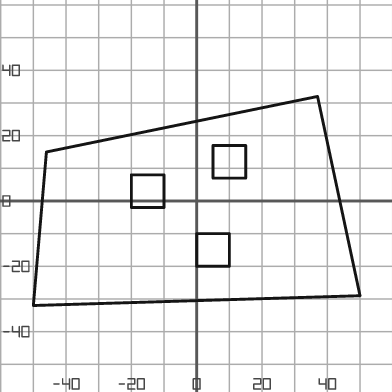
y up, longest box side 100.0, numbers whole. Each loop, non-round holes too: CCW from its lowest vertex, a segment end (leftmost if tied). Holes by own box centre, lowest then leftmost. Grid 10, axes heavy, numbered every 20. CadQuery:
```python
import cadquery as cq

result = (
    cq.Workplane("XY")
    .moveTo(-50.0, -32.0)
    .lineTo(50.0, -29.0)
    .lineTo(37.0, 32.0)
    .lineTo(-46.0, 15.0)
    .close()
    .moveTo(0.0, -20.0)
    .lineTo(10.0, -20.0)
    .lineTo(10.0, -10.0)
    .lineTo(0.0, -10.0)
    .close()
    .moveTo(-20.0, -2.0)
    .lineTo(-10.0, -2.0)
    .lineTo(-10.0, 8.0)
    .lineTo(-20.0, 8.0)
    .close()
    .moveTo(5.0, 7.0)
    .lineTo(15.0, 7.0)
    .lineTo(15.0, 17.0)
    .lineTo(5.0, 17.0)
    .close()
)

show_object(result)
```